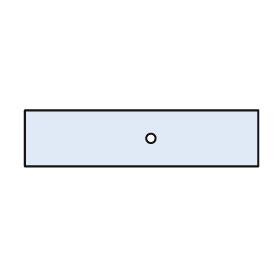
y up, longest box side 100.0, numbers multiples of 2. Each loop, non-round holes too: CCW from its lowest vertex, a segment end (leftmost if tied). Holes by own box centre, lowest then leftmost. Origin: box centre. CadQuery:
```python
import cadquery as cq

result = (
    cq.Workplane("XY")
    .moveTo(-50.0, -12.0)
    .lineTo(50.0, -12.0)
    .lineTo(50.0, 12.0)
    .lineTo(-50.0, 12.0)
    .close()
    .moveTo(4.0, 0.0)
    .circle(2.0)
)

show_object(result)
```